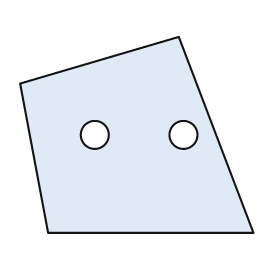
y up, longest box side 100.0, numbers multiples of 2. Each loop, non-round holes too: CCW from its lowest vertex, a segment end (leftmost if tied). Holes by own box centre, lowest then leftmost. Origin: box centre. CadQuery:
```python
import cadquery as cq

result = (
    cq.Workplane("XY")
    .moveTo(-38.0, -42.0)
    .lineTo(50.0, -42.0)
    .lineTo(18.0, 42.0)
    .lineTo(-50.0, 22.0)
    .close()
    .moveTo(-18.0, 0.0)
    .circle(6.0)
    .moveTo(20.0, 0.0)
    .circle(6.0)
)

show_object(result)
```